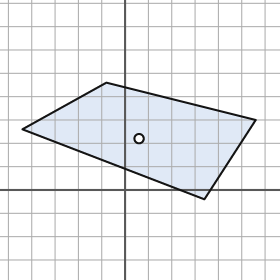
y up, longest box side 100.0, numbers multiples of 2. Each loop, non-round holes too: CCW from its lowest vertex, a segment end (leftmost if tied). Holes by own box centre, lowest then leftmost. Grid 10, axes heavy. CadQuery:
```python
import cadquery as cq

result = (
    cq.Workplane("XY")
    .moveTo(34.0, -4.0)
    .lineTo(56.0, 30.0)
    .lineTo(-8.0, 46.0)
    .lineTo(-44.0, 26.0)
    .close()
    .moveTo(6.0, 22.0)
    .circle(2.0)
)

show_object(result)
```